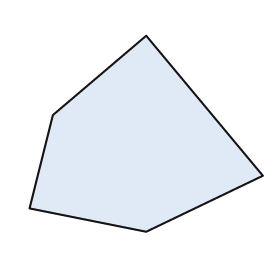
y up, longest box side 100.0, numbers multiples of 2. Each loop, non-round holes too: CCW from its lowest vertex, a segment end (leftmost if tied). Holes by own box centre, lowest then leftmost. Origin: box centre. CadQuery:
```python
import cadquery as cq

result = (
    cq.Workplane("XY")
    .moveTo(0.0, -42.0)
    .lineTo(50.0, -18.0)
    .lineTo(0.0, 42.0)
    .lineTo(-40.0, 8.0)
    .lineTo(-50.0, -32.0)
    .close()
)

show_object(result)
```